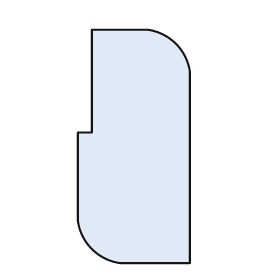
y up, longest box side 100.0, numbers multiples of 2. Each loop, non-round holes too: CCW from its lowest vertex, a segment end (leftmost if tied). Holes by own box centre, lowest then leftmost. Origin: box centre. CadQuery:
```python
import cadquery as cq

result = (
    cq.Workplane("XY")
    .moveTo(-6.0, -50.0)
    .lineTo(24.0, -50.0)
    .lineTo(24.0, 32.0)
    .threePointArc((18.0, 44.0), (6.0, 50.0))
    .lineTo(-18.0, 50.0)
    .lineTo(-18.0, 6.0)
    .lineTo(-24.0, 6.0)
    .lineTo(-24.0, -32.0)
    .threePointArc((-18.0, -44.0), (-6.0, -50.0))
    .close()
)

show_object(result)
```